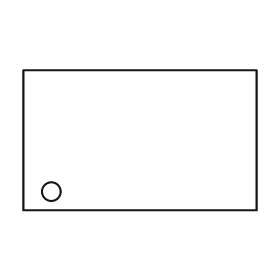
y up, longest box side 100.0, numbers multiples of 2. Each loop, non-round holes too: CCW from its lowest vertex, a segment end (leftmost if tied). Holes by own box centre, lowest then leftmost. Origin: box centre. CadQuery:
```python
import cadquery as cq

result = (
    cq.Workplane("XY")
    .moveTo(-50.0, -30.0)
    .lineTo(50.0, -30.0)
    .lineTo(50.0, 30.0)
    .lineTo(-50.0, 30.0)
    .close()
    .moveTo(-38.0, -22.0)
    .circle(4.0)
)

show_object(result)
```